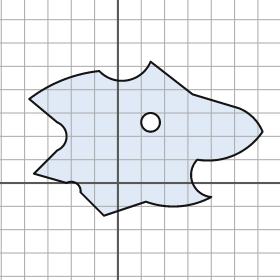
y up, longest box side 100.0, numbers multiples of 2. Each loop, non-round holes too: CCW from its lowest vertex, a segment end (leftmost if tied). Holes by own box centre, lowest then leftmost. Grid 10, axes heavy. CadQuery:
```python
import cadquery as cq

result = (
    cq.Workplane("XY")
    .moveTo(-6.0, -14.0)
    .lineTo(12.0, -8.0)
    .threePointArc((26.0, -10.0), (40.0, -6.0))
    .threePointArc((32.0, 0.0), (34.0, 10.0))
    .threePointArc((50.0, 12.0), (62.0, 22.0))
    .threePointArc((58.0, 28.0), (52.0, 32.0))
    .lineTo(32.0, 38.0)
    .lineTo(14.0, 52.0)
    .threePointArc((4.0, 44.0), (-8.0, 48.0))
    .threePointArc((-24.0, 44.0), (-38.0, 36.0))
    .lineTo(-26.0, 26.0)
    .threePointArc((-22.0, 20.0), (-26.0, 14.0))
    .lineTo(-36.0, 4.0)
    .lineTo(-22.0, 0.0)
    .threePointArc((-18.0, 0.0), (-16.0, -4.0))
    .close()
    .moveTo(14.0, 26.0)
    .circle(4.0)
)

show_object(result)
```